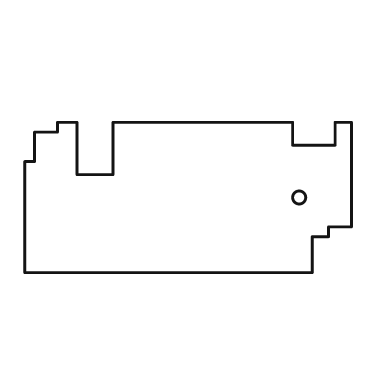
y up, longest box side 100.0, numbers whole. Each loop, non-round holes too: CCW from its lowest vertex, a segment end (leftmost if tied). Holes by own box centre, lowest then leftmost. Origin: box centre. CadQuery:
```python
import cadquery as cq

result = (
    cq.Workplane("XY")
    .moveTo(-50.0, -23.0)
    .lineTo(38.0, -23.0)
    .lineTo(38.0, -12.0)
    .lineTo(43.0, -12.0)
    .lineTo(43.0, -9.0)
    .lineTo(50.0, -9.0)
    .lineTo(50.0, 23.0)
    .lineTo(45.0, 23.0)
    .lineTo(45.0, 16.0)
    .lineTo(32.0, 16.0)
    .lineTo(32.0, 23.0)
    .lineTo(-23.0, 23.0)
    .lineTo(-23.0, 7.0)
    .lineTo(-34.0, 7.0)
    .lineTo(-34.0, 23.0)
    .lineTo(-40.0, 23.0)
    .lineTo(-40.0, 20.0)
    .lineTo(-47.0, 20.0)
    .lineTo(-47.0, 11.0)
    .lineTo(-50.0, 11.0)
    .close()
    .moveTo(34.0, 0.0)
    .circle(2.0)
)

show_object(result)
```